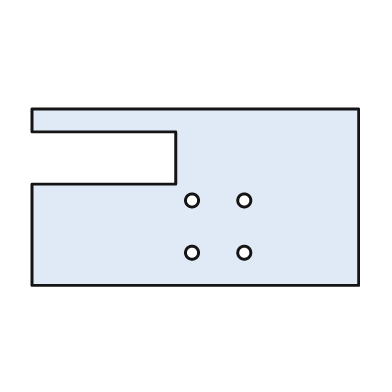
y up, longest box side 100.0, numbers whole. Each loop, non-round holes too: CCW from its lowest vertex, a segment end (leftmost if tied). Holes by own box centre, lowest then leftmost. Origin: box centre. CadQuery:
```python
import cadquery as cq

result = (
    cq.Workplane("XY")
    .moveTo(-50.0, -27.0)
    .lineTo(50.0, -27.0)
    .lineTo(50.0, 27.0)
    .lineTo(-50.0, 27.0)
    .lineTo(-50.0, 20.0)
    .lineTo(-6.0, 20.0)
    .lineTo(-6.0, 4.0)
    .lineTo(-50.0, 4.0)
    .close()
    .moveTo(-1.0, -17.0)
    .circle(2.0)
    .moveTo(15.0, -17.0)
    .circle(2.0)
    .moveTo(-1.0, -1.0)
    .circle(2.0)
    .moveTo(15.0, -1.0)
    .circle(2.0)
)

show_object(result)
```